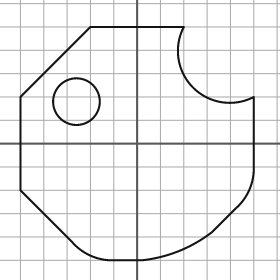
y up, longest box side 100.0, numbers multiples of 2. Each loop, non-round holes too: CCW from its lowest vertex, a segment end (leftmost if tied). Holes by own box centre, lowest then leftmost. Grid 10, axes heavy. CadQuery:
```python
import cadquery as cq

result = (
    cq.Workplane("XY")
    .moveTo(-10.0, -50.0)
    .lineTo(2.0, -50.0)
    .threePointArc((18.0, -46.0), (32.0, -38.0))
    .lineTo(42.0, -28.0)
    .threePointArc((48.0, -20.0), (50.0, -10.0))
    .lineTo(50.0, 20.0)
    .threePointArc((24.0, 24.0), (20.0, 50.0))
    .lineTo(-20.0, 50.0)
    .lineTo(-50.0, 20.0)
    .lineTo(-50.0, -20.0)
    .lineTo(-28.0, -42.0)
    .threePointArc((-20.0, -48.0), (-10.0, -50.0))
    .close()
    .moveTo(-26.0, 18.0)
    .circle(10.0)
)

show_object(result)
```